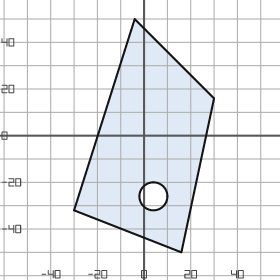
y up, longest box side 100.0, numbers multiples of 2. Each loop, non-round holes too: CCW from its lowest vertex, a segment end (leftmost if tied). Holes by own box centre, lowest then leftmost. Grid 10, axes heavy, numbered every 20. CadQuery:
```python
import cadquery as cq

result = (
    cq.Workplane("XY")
    .moveTo(16.0, -50.0)
    .lineTo(30.0, 16.0)
    .lineTo(-4.0, 50.0)
    .lineTo(-30.0, -32.0)
    .close()
    .moveTo(4.0, -26.0)
    .circle(6.0)
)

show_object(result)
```